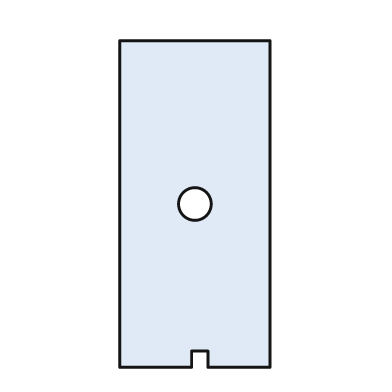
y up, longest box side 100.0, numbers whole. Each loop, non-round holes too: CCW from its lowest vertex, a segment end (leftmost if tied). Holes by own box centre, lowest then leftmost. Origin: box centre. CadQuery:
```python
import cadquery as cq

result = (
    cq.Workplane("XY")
    .moveTo(-23.0, -50.0)
    .lineTo(-1.0, -50.0)
    .lineTo(-1.0, -45.0)
    .lineTo(4.0, -45.0)
    .lineTo(4.0, -50.0)
    .lineTo(23.0, -50.0)
    .lineTo(23.0, 50.0)
    .lineTo(-23.0, 50.0)
    .close()
    .moveTo(0.0, 0.0)
    .circle(5.0)
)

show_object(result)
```